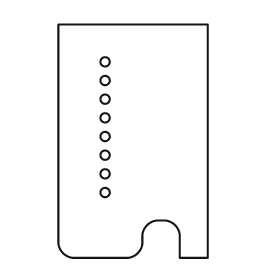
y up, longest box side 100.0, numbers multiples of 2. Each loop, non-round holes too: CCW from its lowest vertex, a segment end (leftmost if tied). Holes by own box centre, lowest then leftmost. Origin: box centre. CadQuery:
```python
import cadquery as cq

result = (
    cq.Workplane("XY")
    .moveTo(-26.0, -50.0)
    .lineTo(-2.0, -50.0)
    .threePointArc((2.0, -48.0), (4.0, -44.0))
    .lineTo(4.0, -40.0)
    .threePointArc((6.0, -36.0), (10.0, -34.0))
    .lineTo(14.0, -34.0)
    .threePointArc((18.0, -36.0), (20.0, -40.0))
    .lineTo(20.0, -50.0)
    .lineTo(32.0, -50.0)
    .lineTo(32.0, 50.0)
    .lineTo(-32.0, 50.0)
    .lineTo(-32.0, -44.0)
    .threePointArc((-30.0, -48.0), (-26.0, -50.0))
    .close()
    .moveTo(-12.0, -22.0)
    .circle(2.0)
    .moveTo(-12.0, -14.0)
    .circle(2.0)
    .moveTo(-12.0, -6.0)
    .circle(2.0)
    .moveTo(-12.0, 2.0)
    .circle(2.0)
    .moveTo(-12.0, 10.0)
    .circle(2.0)
    .moveTo(-12.0, 18.0)
    .circle(2.0)
    .moveTo(-12.0, 26.0)
    .circle(2.0)
    .moveTo(-12.0, 34.0)
    .circle(2.0)
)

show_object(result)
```